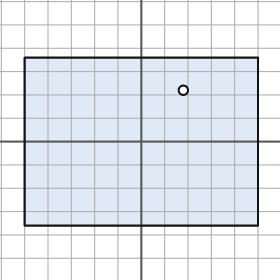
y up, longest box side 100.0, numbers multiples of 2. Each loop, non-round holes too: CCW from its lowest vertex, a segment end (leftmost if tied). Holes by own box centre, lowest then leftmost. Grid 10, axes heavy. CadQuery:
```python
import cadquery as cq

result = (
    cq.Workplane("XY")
    .moveTo(-50.0, -36.0)
    .lineTo(50.0, -36.0)
    .lineTo(50.0, 36.0)
    .lineTo(-50.0, 36.0)
    .close()
    .moveTo(18.0, 22.0)
    .circle(2.0)
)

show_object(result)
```